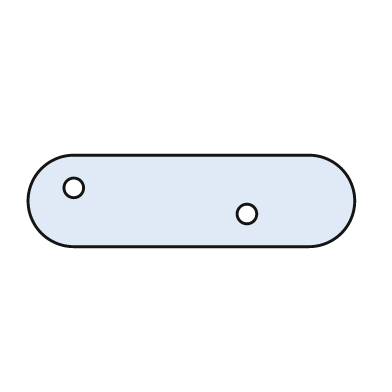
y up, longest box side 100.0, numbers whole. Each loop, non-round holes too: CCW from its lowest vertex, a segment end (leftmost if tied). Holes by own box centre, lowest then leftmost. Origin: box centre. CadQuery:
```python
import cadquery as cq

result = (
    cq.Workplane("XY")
    .moveTo(-36.0, -14.0)
    .lineTo(36.0, -14.0)
    .threePointArc((50.0, 0.0), (36.0, 14.0))
    .lineTo(-36.0, 14.0)
    .threePointArc((-50.0, 0.0), (-36.0, -14.0))
    .close()
    .moveTo(17.0, -4.0)
    .circle(3.0)
    .moveTo(-36.0, 4.0)
    .circle(3.0)
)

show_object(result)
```